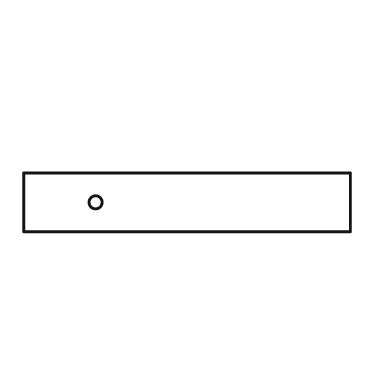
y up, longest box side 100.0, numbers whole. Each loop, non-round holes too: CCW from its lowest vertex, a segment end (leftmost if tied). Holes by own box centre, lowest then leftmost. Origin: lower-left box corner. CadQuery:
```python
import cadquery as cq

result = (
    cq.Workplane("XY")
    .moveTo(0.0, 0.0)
    .lineTo(100.0, 0.0)
    .lineTo(100.0, 18.0)
    .lineTo(0.0, 18.0)
    .close()
    .moveTo(22.0, 9.0)
    .circle(2.0)
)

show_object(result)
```